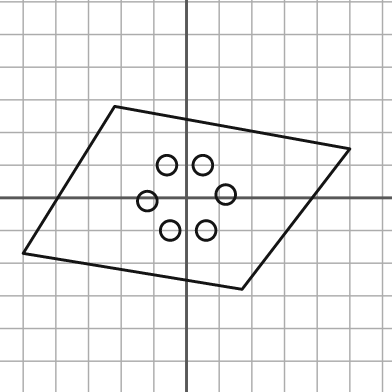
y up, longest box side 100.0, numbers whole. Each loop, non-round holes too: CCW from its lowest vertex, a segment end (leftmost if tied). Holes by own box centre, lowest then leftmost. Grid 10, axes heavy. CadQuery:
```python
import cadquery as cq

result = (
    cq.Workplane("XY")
    .moveTo(17.0, -28.0)
    .lineTo(50.0, 15.0)
    .lineTo(-22.0, 28.0)
    .lineTo(-50.0, -17.0)
    .close()
    .moveTo(-5.0, -10.0)
    .circle(3.0)
    .moveTo(6.0, -10.0)
    .circle(3.0)
    .moveTo(-12.0, -1.0)
    .circle(3.0)
    .moveTo(12.0, 1.0)
    .circle(3.0)
    .moveTo(-6.0, 10.0)
    .circle(3.0)
    .moveTo(5.0, 10.0)
    .circle(3.0)
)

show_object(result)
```